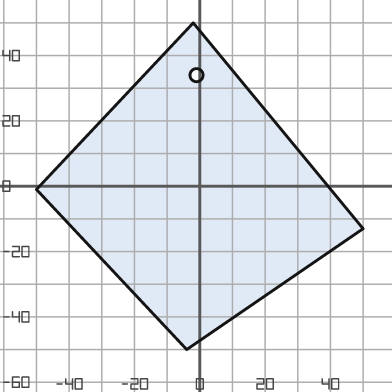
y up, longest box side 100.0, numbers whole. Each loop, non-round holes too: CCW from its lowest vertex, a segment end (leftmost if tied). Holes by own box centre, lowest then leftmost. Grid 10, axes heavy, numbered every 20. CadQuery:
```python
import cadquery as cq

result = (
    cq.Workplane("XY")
    .moveTo(-4.0, -50.0)
    .lineTo(50.0, -13.0)
    .lineTo(-2.0, 50.0)
    .lineTo(-50.0, -1.0)
    .close()
    .moveTo(-1.0, 34.0)
    .circle(2.0)
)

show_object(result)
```